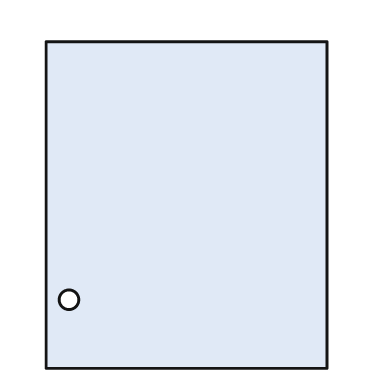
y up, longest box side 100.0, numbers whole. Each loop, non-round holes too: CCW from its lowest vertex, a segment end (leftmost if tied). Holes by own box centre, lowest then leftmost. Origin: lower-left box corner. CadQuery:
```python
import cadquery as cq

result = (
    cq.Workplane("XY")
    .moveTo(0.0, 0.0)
    .lineTo(86.0, 0.0)
    .lineTo(86.0, 100.0)
    .lineTo(0.0, 100.0)
    .close()
    .moveTo(7.0, 21.0)
    .circle(3.0)
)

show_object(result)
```